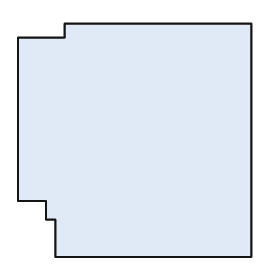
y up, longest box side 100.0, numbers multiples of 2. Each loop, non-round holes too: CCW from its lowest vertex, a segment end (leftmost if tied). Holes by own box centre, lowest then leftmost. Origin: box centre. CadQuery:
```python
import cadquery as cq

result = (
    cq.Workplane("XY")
    .moveTo(-34.0, -50.0)
    .lineTo(50.0, -50.0)
    .lineTo(50.0, 50.0)
    .lineTo(-30.0, 50.0)
    .lineTo(-30.0, 44.0)
    .lineTo(-50.0, 44.0)
    .lineTo(-50.0, -26.0)
    .lineTo(-38.0, -26.0)
    .lineTo(-38.0, -34.0)
    .lineTo(-34.0, -34.0)
    .close()
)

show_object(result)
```